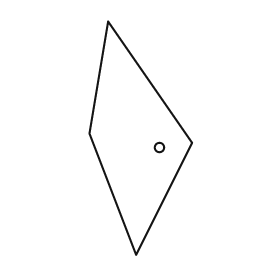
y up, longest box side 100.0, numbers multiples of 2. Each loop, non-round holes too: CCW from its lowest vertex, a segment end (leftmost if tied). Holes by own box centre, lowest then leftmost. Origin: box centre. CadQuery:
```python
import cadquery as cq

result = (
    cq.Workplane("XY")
    .moveTo(-2.0, -50.0)
    .lineTo(22.0, -2.0)
    .lineTo(-14.0, 50.0)
    .lineTo(-22.0, 2.0)
    .close()
    .moveTo(8.0, -4.0)
    .circle(2.0)
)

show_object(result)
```